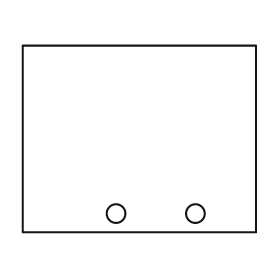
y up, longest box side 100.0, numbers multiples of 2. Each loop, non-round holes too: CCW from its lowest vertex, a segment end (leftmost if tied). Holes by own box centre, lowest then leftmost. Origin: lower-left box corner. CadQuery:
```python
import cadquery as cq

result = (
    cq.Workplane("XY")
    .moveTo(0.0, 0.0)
    .lineTo(100.0, 0.0)
    .lineTo(100.0, 80.0)
    .lineTo(0.0, 80.0)
    .close()
    .moveTo(40.0, 8.0)
    .circle(4.0)
    .moveTo(74.0, 8.0)
    .circle(4.0)
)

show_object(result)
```